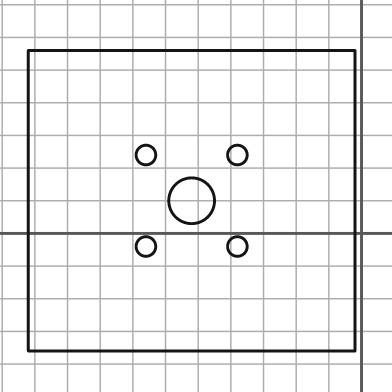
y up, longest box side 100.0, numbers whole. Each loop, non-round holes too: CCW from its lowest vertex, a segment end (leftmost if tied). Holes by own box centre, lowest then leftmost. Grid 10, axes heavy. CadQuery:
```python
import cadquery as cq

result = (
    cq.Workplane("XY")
    .moveTo(-102.0, -36.0)
    .lineTo(-2.0, -36.0)
    .lineTo(-2.0, 56.0)
    .lineTo(-102.0, 56.0)
    .close()
    .moveTo(-66.0, -4.0)
    .circle(3.0)
    .moveTo(-38.0, -4.0)
    .circle(3.0)
    .moveTo(-52.0, 10.0)
    .circle(7.0)
    .moveTo(-66.0, 24.0)
    .circle(3.0)
    .moveTo(-38.0, 24.0)
    .circle(3.0)
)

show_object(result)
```